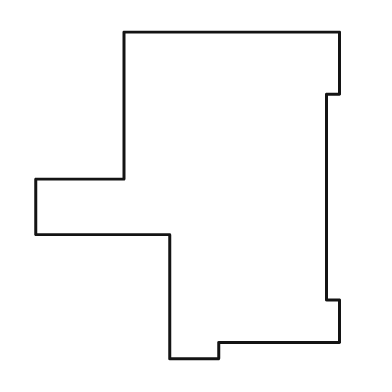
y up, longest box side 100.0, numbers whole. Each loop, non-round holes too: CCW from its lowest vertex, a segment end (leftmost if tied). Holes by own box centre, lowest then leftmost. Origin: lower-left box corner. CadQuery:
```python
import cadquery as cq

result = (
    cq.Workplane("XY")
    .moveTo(41.0, 0.0)
    .lineTo(56.0, 0.0)
    .lineTo(56.0, 5.0)
    .lineTo(93.0, 5.0)
    .lineTo(93.0, 18.0)
    .lineTo(89.0, 18.0)
    .lineTo(89.0, 81.0)
    .lineTo(93.0, 81.0)
    .lineTo(93.0, 100.0)
    .lineTo(27.0, 100.0)
    .lineTo(27.0, 55.0)
    .lineTo(0.0, 55.0)
    .lineTo(0.0, 38.0)
    .lineTo(41.0, 38.0)
    .close()
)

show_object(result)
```